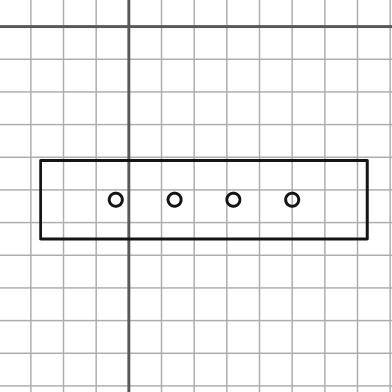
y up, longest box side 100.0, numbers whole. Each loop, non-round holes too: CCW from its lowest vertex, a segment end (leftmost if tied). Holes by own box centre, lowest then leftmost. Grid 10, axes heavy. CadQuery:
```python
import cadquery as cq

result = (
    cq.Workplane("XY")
    .moveTo(-27.0, -65.0)
    .lineTo(73.0, -65.0)
    .lineTo(73.0, -41.0)
    .lineTo(-27.0, -41.0)
    .close()
    .moveTo(-4.0, -53.0)
    .circle(2.0)
    .moveTo(14.0, -53.0)
    .circle(2.0)
    .moveTo(32.0, -53.0)
    .circle(2.0)
    .moveTo(50.0, -53.0)
    .circle(2.0)
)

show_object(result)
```